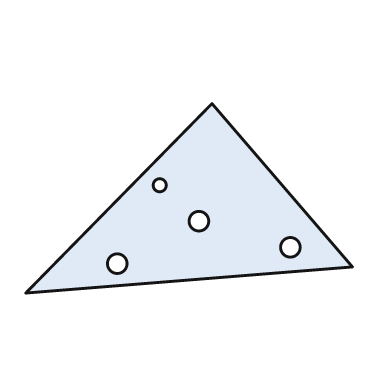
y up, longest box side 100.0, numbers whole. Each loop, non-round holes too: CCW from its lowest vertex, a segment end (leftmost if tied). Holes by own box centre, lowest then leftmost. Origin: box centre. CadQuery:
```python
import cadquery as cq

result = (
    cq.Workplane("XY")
    .moveTo(-50.0, -29.0)
    .lineTo(50.0, -21.0)
    .lineTo(7.0, 29.0)
    .close()
    .moveTo(-22.0, -20.0)
    .circle(3.0)
    .moveTo(31.0, -15.0)
    .circle(3.0)
    .moveTo(3.0, -7.0)
    .circle(3.0)
    .moveTo(-9.0, 4.0)
    .circle(2.0)
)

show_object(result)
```